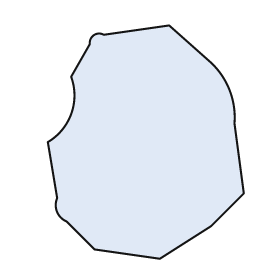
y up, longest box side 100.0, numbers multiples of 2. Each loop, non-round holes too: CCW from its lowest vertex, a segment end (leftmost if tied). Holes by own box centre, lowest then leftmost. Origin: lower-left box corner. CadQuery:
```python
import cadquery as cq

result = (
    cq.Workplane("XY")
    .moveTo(48.0, 0.0)
    .lineTo(70.0, 14.0)
    .lineTo(84.0, 28.0)
    .lineTo(80.0, 58.0)
    .threePointArc((78.0, 72.0), (70.0, 84.0))
    .lineTo(52.0, 100.0)
    .lineTo(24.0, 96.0)
    .threePointArc((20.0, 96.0), (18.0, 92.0))
    .lineTo(10.0, 78.0)
    .threePointArc((10.0, 62.0), (0.0, 50.0))
    .lineTo(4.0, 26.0)
    .threePointArc((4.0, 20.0), (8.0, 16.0))
    .lineTo(20.0, 4.0)
    .close()
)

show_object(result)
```